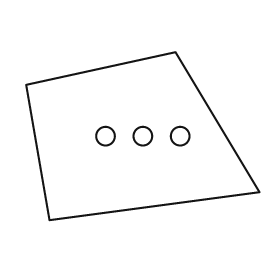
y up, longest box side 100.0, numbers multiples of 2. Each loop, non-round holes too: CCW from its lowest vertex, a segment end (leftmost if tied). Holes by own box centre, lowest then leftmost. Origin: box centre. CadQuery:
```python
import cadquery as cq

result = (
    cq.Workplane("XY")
    .moveTo(-40.0, -36.0)
    .lineTo(50.0, -24.0)
    .lineTo(14.0, 36.0)
    .lineTo(-50.0, 22.0)
    .close()
    .moveTo(-16.0, 0.0)
    .circle(4.0)
    .moveTo(0.0, 0.0)
    .circle(4.0)
    .moveTo(16.0, 0.0)
    .circle(4.0)
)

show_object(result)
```